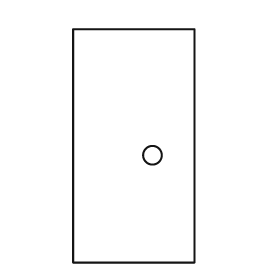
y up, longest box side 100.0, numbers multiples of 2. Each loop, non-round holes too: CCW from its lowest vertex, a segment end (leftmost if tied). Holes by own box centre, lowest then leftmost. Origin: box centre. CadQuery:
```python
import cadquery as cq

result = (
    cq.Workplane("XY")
    .moveTo(-26.0, -50.0)
    .lineTo(26.0, -50.0)
    .lineTo(26.0, 50.0)
    .lineTo(-26.0, 50.0)
    .close()
    .moveTo(8.0, -4.0)
    .circle(4.0)
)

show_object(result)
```